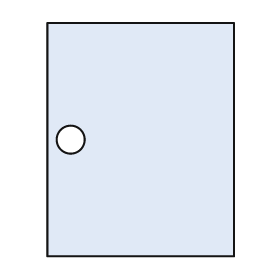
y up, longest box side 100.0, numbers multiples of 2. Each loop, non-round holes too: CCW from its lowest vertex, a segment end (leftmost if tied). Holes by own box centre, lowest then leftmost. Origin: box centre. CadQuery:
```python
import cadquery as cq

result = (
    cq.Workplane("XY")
    .moveTo(-40.0, -50.0)
    .lineTo(40.0, -50.0)
    .lineTo(40.0, 50.0)
    .lineTo(-40.0, 50.0)
    .close()
    .moveTo(-30.0, 0.0)
    .circle(6.0)
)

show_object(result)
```